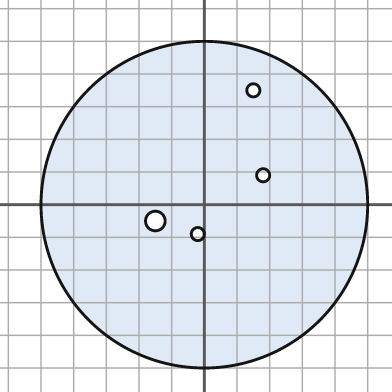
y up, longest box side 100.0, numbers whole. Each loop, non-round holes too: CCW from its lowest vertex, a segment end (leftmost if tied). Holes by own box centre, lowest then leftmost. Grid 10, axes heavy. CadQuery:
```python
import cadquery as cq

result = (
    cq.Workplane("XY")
    .moveTo(0.0, 0.0)
    .circle(50.0)
    .moveTo(-2.0, -9.0)
    .circle(2.0)
    .moveTo(-15.0, -5.0)
    .circle(3.0)
    .moveTo(18.0, 9.0)
    .circle(2.0)
    .moveTo(15.0, 35.0)
    .circle(2.0)
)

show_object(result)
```